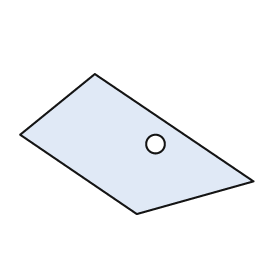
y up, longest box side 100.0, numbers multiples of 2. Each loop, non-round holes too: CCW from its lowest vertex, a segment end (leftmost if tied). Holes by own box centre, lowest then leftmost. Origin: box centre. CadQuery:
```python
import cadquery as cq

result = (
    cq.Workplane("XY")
    .moveTo(0.0, -30.0)
    .lineTo(50.0, -16.0)
    .lineTo(-18.0, 30.0)
    .lineTo(-50.0, 4.0)
    .close()
    .moveTo(8.0, 0.0)
    .circle(4.0)
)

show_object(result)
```